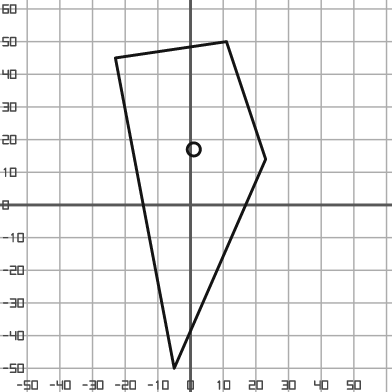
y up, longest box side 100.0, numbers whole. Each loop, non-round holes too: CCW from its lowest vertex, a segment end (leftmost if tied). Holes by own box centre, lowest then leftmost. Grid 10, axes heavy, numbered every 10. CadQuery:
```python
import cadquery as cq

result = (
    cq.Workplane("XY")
    .moveTo(-5.0, -50.0)
    .lineTo(23.0, 14.0)
    .lineTo(11.0, 50.0)
    .lineTo(-23.0, 45.0)
    .close()
    .moveTo(1.0, 17.0)
    .circle(2.0)
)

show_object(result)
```